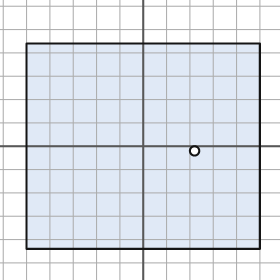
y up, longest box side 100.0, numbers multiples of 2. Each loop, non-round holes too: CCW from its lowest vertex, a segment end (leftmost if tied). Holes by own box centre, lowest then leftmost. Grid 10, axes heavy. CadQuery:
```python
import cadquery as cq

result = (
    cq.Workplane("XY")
    .moveTo(-50.0, -44.0)
    .lineTo(50.0, -44.0)
    .lineTo(50.0, 44.0)
    .lineTo(-50.0, 44.0)
    .close()
    .moveTo(22.0, -2.0)
    .circle(2.0)
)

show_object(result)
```